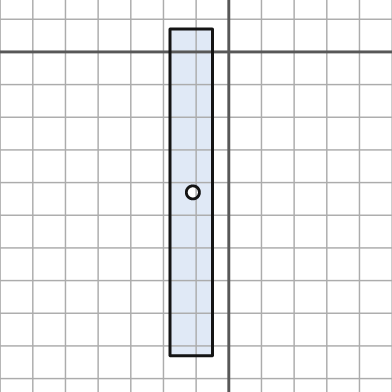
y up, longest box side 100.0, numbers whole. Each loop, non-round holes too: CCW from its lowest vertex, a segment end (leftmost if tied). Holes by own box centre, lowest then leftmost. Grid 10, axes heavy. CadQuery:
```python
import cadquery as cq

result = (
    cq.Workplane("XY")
    .moveTo(-18.0, -93.0)
    .lineTo(-5.0, -93.0)
    .lineTo(-5.0, 7.0)
    .lineTo(-18.0, 7.0)
    .close()
    .moveTo(-11.0, -43.0)
    .circle(2.0)
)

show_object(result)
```